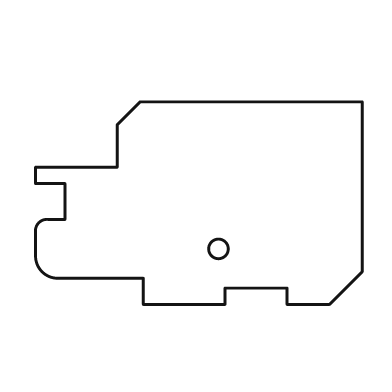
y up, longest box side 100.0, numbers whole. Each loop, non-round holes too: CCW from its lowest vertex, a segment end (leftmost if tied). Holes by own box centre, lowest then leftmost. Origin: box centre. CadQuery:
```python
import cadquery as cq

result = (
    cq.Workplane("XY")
    .moveTo(-17.0, -31.0)
    .lineTo(8.0, -31.0)
    .lineTo(8.0, -26.0)
    .lineTo(27.0, -26.0)
    .lineTo(27.0, -31.0)
    .lineTo(40.0, -31.0)
    .lineTo(50.0, -21.0)
    .lineTo(50.0, 31.0)
    .lineTo(-18.0, 31.0)
    .lineTo(-25.0, 24.0)
    .lineTo(-25.0, 11.0)
    .lineTo(-50.0, 11.0)
    .lineTo(-50.0, 6.0)
    .lineTo(-41.0, 6.0)
    .lineTo(-41.0, -5.0)
    .lineTo(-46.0, -5.0)
    .threePointArc((-49.0, -6.0), (-50.0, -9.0))
    .lineTo(-50.0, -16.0)
    .threePointArc((-48.0, -21.0), (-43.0, -23.0))
    .lineTo(-17.0, -23.0)
    .close()
    .moveTo(6.0, -14.0)
    .circle(3.0)
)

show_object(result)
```